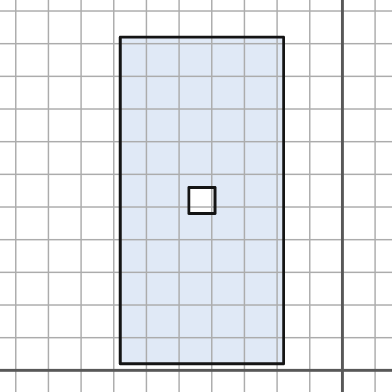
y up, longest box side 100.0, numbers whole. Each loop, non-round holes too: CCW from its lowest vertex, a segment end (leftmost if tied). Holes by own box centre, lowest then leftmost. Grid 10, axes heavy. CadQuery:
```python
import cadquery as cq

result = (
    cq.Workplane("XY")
    .moveTo(-68.0, 2.0)
    .lineTo(-18.0, 2.0)
    .lineTo(-18.0, 102.0)
    .lineTo(-68.0, 102.0)
    .close()
    .moveTo(-47.0, 48.0)
    .lineTo(-39.0, 48.0)
    .lineTo(-39.0, 56.0)
    .lineTo(-47.0, 56.0)
    .close()
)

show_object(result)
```